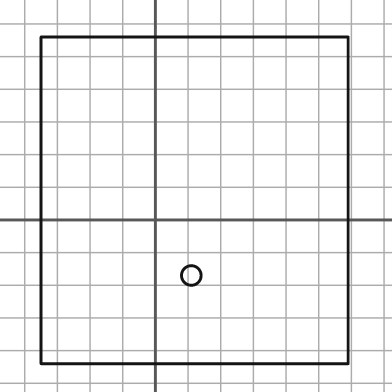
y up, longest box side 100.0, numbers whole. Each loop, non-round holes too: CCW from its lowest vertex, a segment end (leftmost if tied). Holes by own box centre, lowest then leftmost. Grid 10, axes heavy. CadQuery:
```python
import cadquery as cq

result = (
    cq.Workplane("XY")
    .moveTo(-35.0, -44.0)
    .lineTo(59.0, -44.0)
    .lineTo(59.0, 56.0)
    .lineTo(-35.0, 56.0)
    .close()
    .moveTo(11.0, -17.0)
    .circle(3.0)
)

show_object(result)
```